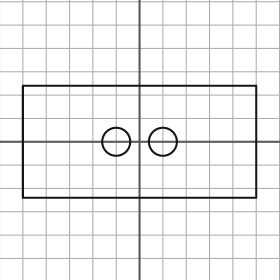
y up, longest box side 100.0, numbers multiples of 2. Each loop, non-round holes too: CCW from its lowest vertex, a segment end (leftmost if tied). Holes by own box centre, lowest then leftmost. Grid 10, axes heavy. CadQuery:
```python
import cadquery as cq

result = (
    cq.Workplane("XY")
    .moveTo(-50.0, -24.0)
    .lineTo(50.0, -24.0)
    .lineTo(50.0, 24.0)
    .lineTo(-50.0, 24.0)
    .close()
    .moveTo(-10.0, 0.0)
    .circle(6.0)
    .moveTo(10.0, 0.0)
    .circle(6.0)
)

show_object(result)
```